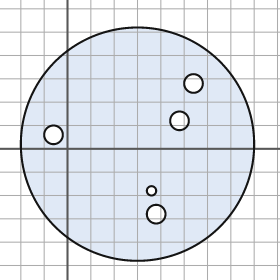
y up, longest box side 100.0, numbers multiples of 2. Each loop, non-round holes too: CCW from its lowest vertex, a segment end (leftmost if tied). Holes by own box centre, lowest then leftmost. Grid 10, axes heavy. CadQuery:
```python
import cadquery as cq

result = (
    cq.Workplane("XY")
    .moveTo(30.0, 2.0)
    .circle(50.0)
    .moveTo(38.0, -28.0)
    .circle(4.0)
    .moveTo(36.0, -18.0)
    .circle(2.0)
    .moveTo(-6.0, 6.0)
    .circle(4.0)
    .moveTo(48.0, 12.0)
    .circle(4.0)
    .moveTo(54.0, 28.0)
    .circle(4.0)
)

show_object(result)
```